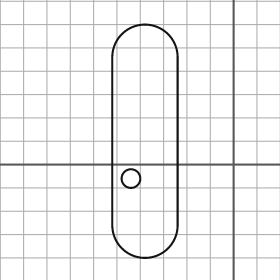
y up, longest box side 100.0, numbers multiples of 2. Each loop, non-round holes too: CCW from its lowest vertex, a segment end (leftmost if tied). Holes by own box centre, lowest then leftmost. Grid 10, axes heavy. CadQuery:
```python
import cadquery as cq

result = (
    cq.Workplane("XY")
    .moveTo(-52.0, -26.0)
    .threePointArc((-38.0, -40.0), (-24.0, -26.0))
    .lineTo(-24.0, 46.0)
    .threePointArc((-38.0, 60.0), (-52.0, 46.0))
    .close()
    .moveTo(-44.0, -6.0)
    .circle(4.0)
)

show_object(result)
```